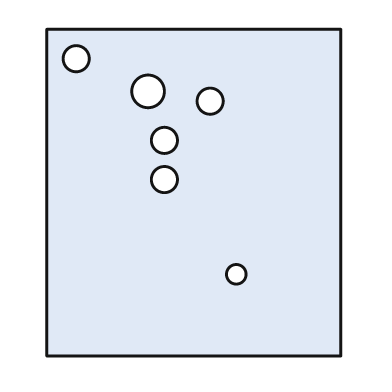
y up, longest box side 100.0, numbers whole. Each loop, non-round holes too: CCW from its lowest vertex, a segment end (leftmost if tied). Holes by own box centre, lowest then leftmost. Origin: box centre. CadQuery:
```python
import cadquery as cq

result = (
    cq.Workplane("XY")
    .moveTo(-45.0, -50.0)
    .lineTo(45.0, -50.0)
    .lineTo(45.0, 50.0)
    .lineTo(-45.0, 50.0)
    .close()
    .moveTo(13.0, -25.0)
    .circle(3.0)
    .moveTo(-9.0, 4.0)
    .circle(4.0)
    .moveTo(-9.0, 16.0)
    .circle(4.0)
    .moveTo(5.0, 28.0)
    .circle(4.0)
    .moveTo(-14.0, 31.0)
    .circle(5.0)
    .moveTo(-36.0, 41.0)
    .circle(4.0)
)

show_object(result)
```